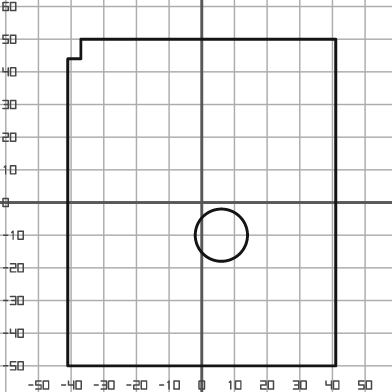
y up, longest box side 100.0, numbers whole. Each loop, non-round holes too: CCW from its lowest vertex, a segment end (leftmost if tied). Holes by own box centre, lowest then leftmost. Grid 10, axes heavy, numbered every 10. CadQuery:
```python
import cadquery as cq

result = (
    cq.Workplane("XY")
    .moveTo(-41.0, -50.0)
    .lineTo(41.0, -50.0)
    .lineTo(41.0, 50.0)
    .lineTo(-37.0, 50.0)
    .lineTo(-37.0, 44.0)
    .lineTo(-41.0, 44.0)
    .close()
    .moveTo(6.0, -10.0)
    .circle(8.0)
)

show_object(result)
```